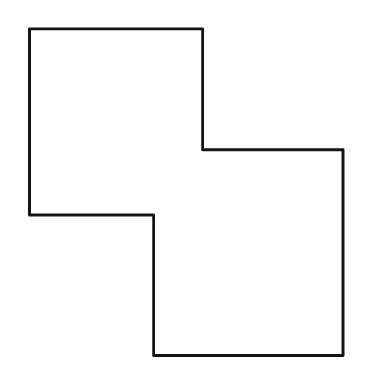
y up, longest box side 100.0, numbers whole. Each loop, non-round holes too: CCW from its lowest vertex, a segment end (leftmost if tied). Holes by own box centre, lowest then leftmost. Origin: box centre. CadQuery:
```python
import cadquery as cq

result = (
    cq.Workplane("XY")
    .moveTo(-10.0, -50.0)
    .lineTo(48.0, -50.0)
    .lineTo(48.0, 13.0)
    .lineTo(5.0, 13.0)
    .lineTo(5.0, 50.0)
    .lineTo(-48.0, 50.0)
    .lineTo(-48.0, -7.0)
    .lineTo(-10.0, -7.0)
    .close()
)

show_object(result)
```